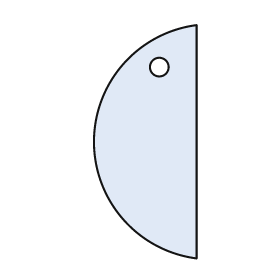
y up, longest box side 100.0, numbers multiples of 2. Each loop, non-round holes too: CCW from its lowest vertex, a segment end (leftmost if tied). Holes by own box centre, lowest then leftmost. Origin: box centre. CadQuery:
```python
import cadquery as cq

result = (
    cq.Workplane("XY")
    .moveTo(22.0, -50.0)
    .lineTo(22.0, 50.0)
    .threePointArc((-22.0, 0.0), (22.0, -50.0))
    .close()
    .moveTo(6.0, 32.0)
    .circle(4.0)
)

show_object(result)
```